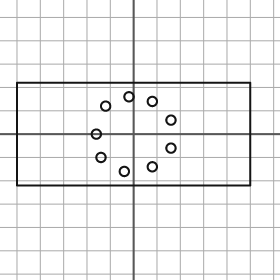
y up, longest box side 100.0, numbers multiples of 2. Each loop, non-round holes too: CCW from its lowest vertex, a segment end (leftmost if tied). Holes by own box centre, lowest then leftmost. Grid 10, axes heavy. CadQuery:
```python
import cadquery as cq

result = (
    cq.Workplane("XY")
    .moveTo(-50.0, -22.0)
    .lineTo(50.0, -22.0)
    .lineTo(50.0, 22.0)
    .lineTo(-50.0, 22.0)
    .close()
    .moveTo(-4.0, -16.0)
    .circle(2.0)
    .moveTo(8.0, -14.0)
    .circle(2.0)
    .moveTo(-14.0, -10.0)
    .circle(2.0)
    .moveTo(16.0, -6.0)
    .circle(2.0)
    .moveTo(-16.0, 0.0)
    .circle(2.0)
    .moveTo(16.0, 6.0)
    .circle(2.0)
    .moveTo(-12.0, 12.0)
    .circle(2.0)
    .moveTo(8.0, 14.0)
    .circle(2.0)
    .moveTo(-2.0, 16.0)
    .circle(2.0)
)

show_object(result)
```